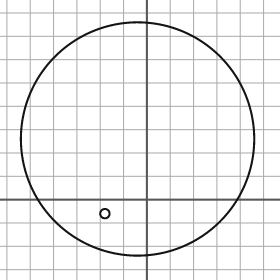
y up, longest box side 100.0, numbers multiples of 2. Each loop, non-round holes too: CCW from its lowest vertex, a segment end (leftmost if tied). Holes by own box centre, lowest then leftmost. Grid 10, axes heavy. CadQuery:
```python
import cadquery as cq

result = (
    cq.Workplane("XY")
    .moveTo(-4.0, 26.0)
    .circle(50.0)
    .moveTo(-18.0, -6.0)
    .circle(2.0)
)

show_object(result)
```